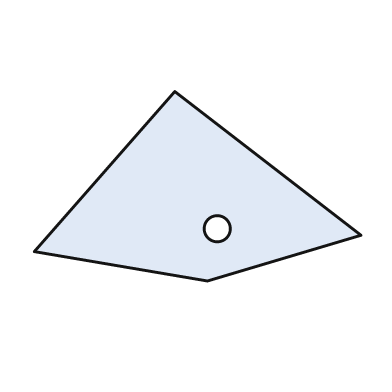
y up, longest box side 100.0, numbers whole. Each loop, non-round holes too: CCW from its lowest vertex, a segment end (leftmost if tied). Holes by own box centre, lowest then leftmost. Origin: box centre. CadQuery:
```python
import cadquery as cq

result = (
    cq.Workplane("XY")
    .moveTo(3.0, -29.0)
    .lineTo(50.0, -15.0)
    .lineTo(-7.0, 29.0)
    .lineTo(-50.0, -20.0)
    .close()
    .moveTo(6.0, -13.0)
    .circle(4.0)
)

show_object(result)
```